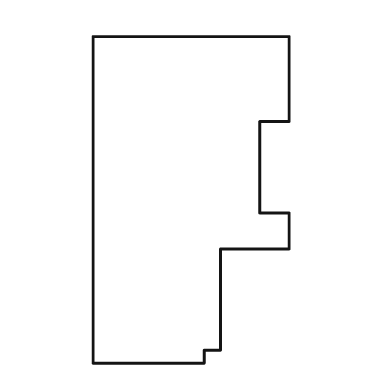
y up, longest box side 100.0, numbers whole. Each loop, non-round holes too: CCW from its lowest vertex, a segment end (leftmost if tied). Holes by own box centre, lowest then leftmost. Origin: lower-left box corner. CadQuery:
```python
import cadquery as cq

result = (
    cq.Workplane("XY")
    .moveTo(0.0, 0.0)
    .lineTo(34.0, 0.0)
    .lineTo(34.0, 4.0)
    .lineTo(39.0, 4.0)
    .lineTo(39.0, 35.0)
    .lineTo(60.0, 35.0)
    .lineTo(60.0, 46.0)
    .lineTo(51.0, 46.0)
    .lineTo(51.0, 74.0)
    .lineTo(60.0, 74.0)
    .lineTo(60.0, 100.0)
    .lineTo(0.0, 100.0)
    .close()
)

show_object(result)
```